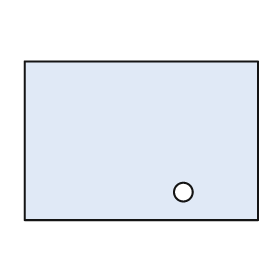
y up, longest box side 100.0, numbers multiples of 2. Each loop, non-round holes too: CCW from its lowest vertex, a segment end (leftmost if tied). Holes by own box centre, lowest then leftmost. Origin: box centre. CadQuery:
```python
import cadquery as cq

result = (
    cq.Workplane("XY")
    .moveTo(-50.0, -34.0)
    .lineTo(50.0, -34.0)
    .lineTo(50.0, 34.0)
    .lineTo(-50.0, 34.0)
    .close()
    .moveTo(18.0, -22.0)
    .circle(4.0)
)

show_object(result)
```